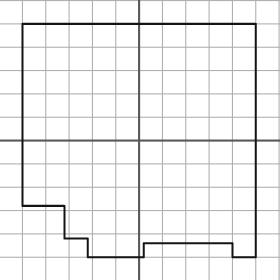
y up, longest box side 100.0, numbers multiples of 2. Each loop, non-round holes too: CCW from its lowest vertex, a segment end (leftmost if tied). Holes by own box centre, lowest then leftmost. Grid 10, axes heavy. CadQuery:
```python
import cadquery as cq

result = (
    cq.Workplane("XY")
    .moveTo(-22.0, -50.0)
    .lineTo(2.0, -50.0)
    .lineTo(2.0, -44.0)
    .lineTo(40.0, -44.0)
    .lineTo(40.0, -50.0)
    .lineTo(50.0, -50.0)
    .lineTo(50.0, 50.0)
    .lineTo(-50.0, 50.0)
    .lineTo(-50.0, -28.0)
    .lineTo(-32.0, -28.0)
    .lineTo(-32.0, -42.0)
    .lineTo(-22.0, -42.0)
    .close()
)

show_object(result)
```